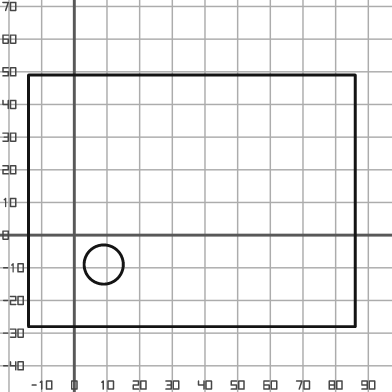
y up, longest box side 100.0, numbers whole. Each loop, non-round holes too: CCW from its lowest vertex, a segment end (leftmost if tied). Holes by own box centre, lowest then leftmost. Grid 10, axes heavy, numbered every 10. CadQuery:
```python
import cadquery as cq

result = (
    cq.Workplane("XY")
    .moveTo(-14.0, -28.0)
    .lineTo(86.0, -28.0)
    .lineTo(86.0, 49.0)
    .lineTo(-14.0, 49.0)
    .close()
    .moveTo(9.0, -9.0)
    .circle(6.0)
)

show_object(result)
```